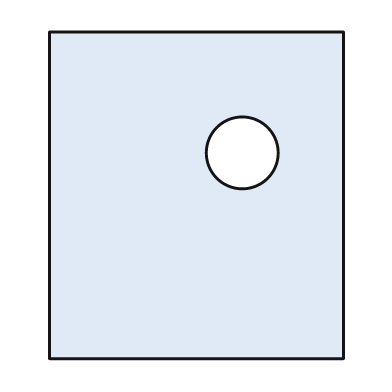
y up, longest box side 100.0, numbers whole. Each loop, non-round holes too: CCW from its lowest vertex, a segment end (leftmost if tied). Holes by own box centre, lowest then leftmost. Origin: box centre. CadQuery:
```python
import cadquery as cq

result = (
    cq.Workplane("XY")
    .moveTo(-45.0, -50.0)
    .lineTo(45.0, -50.0)
    .lineTo(45.0, 50.0)
    .lineTo(-45.0, 50.0)
    .close()
    .moveTo(14.0, 13.0)
    .circle(11.0)
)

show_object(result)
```